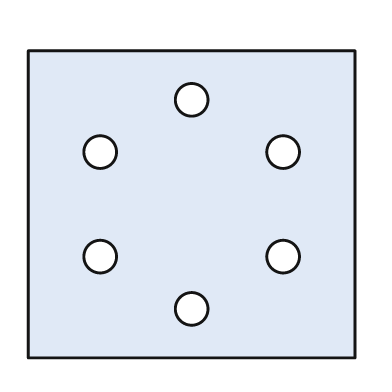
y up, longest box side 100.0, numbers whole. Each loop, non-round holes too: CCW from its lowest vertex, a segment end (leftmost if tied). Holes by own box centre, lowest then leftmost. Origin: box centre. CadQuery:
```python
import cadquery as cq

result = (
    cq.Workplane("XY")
    .moveTo(-50.0, -47.0)
    .lineTo(50.0, -47.0)
    .lineTo(50.0, 47.0)
    .lineTo(-50.0, 47.0)
    .close()
    .moveTo(0.0, -32.0)
    .circle(5.0)
    .moveTo(-28.0, -16.0)
    .circle(5.0)
    .moveTo(28.0, -16.0)
    .circle(5.0)
    .moveTo(-28.0, 16.0)
    .circle(5.0)
    .moveTo(28.0, 16.0)
    .circle(5.0)
    .moveTo(0.0, 32.0)
    .circle(5.0)
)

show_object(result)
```